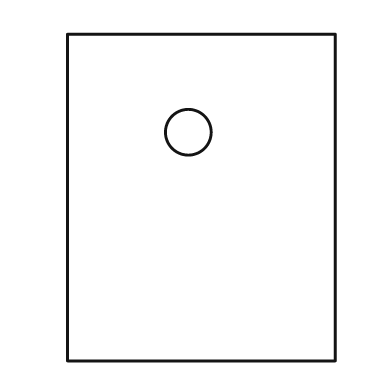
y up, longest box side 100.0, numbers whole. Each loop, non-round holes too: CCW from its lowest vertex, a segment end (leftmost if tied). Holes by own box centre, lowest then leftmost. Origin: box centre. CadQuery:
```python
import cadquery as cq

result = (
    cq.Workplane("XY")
    .moveTo(-41.0, -50.0)
    .lineTo(41.0, -50.0)
    .lineTo(41.0, 50.0)
    .lineTo(-41.0, 50.0)
    .close()
    .moveTo(-4.0, 20.0)
    .circle(7.0)
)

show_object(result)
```